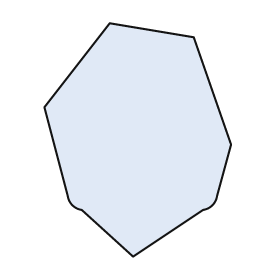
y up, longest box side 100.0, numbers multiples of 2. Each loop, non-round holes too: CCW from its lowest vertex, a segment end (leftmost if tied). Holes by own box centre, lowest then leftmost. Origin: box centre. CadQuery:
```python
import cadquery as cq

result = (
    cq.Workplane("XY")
    .moveTo(-2.0, -50.0)
    .lineTo(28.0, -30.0)
    .threePointArc((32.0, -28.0), (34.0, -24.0))
    .lineTo(40.0, -2.0)
    .lineTo(24.0, 44.0)
    .lineTo(-12.0, 50.0)
    .lineTo(-40.0, 14.0)
    .lineTo(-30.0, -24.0)
    .threePointArc((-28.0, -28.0), (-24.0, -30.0))
    .close()
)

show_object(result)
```